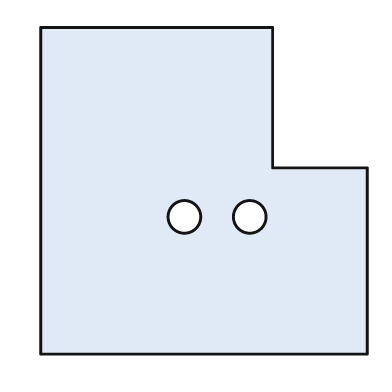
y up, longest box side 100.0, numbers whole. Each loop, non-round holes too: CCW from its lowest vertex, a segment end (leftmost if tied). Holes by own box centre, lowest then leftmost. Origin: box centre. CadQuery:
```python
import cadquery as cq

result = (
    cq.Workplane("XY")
    .moveTo(-50.0, -50.0)
    .lineTo(50.0, -50.0)
    .lineTo(50.0, 7.0)
    .lineTo(21.0, 7.0)
    .lineTo(21.0, 50.0)
    .lineTo(-50.0, 50.0)
    .close()
    .moveTo(-6.0, -8.0)
    .circle(5.0)
    .moveTo(14.0, -8.0)
    .circle(5.0)
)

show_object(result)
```